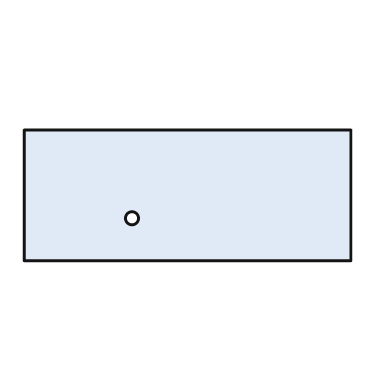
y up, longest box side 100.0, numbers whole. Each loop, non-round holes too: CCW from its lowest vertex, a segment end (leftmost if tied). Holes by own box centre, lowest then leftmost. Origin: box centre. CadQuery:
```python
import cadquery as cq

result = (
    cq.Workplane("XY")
    .moveTo(-50.0, -20.0)
    .lineTo(50.0, -20.0)
    .lineTo(50.0, 20.0)
    .lineTo(-50.0, 20.0)
    .close()
    .moveTo(-17.0, -7.0)
    .circle(2.0)
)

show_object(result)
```